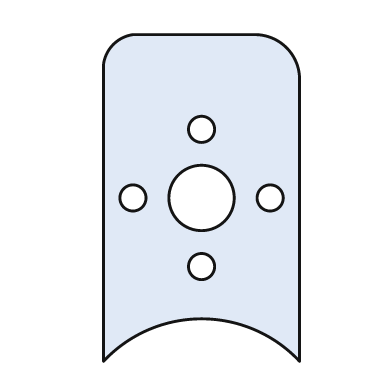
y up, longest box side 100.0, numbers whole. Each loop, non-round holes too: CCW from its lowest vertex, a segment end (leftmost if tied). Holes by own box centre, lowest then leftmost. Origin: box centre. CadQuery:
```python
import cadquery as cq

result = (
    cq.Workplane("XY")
    .moveTo(-30.0, -50.0)
    .threePointArc((0.0, -37.0), (30.0, -50.0))
    .lineTo(30.0, 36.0)
    .threePointArc((26.0, 46.0), (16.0, 50.0))
    .lineTo(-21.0, 50.0)
    .threePointArc((-27.0, 47.0), (-30.0, 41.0))
    .close()
    .moveTo(0.0, -21.0)
    .circle(4.0)
    .moveTo(-21.0, 0.0)
    .circle(4.0)
    .moveTo(0.0, 0.0)
    .circle(10.0)
    .moveTo(21.0, 0.0)
    .circle(4.0)
    .moveTo(0.0, 21.0)
    .circle(4.0)
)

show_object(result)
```